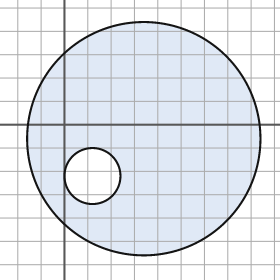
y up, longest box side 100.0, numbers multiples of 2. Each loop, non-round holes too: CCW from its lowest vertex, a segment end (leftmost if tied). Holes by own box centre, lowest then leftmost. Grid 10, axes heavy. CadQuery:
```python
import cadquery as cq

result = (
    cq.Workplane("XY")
    .moveTo(34.0, -6.0)
    .circle(50.0)
    .moveTo(12.0, -22.0)
    .circle(12.0)
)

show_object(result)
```